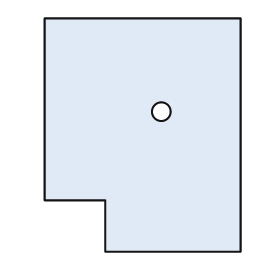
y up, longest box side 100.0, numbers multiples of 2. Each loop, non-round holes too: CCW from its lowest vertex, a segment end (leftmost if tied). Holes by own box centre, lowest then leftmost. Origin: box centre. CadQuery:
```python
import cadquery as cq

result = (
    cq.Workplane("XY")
    .moveTo(-16.0, -50.0)
    .lineTo(42.0, -50.0)
    .lineTo(42.0, 50.0)
    .lineTo(-42.0, 50.0)
    .lineTo(-42.0, -28.0)
    .lineTo(-16.0, -28.0)
    .close()
    .moveTo(8.0, 10.0)
    .circle(4.0)
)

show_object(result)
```